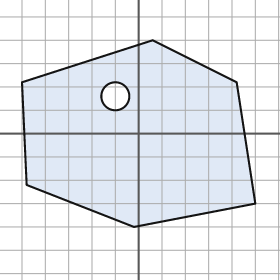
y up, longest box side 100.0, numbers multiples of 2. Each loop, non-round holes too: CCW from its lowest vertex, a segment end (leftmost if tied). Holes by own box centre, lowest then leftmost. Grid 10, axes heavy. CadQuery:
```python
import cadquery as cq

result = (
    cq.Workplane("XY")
    .moveTo(-2.0, -40.0)
    .lineTo(50.0, -30.0)
    .lineTo(42.0, 22.0)
    .lineTo(6.0, 40.0)
    .lineTo(-50.0, 22.0)
    .lineTo(-48.0, -22.0)
    .close()
    .moveTo(-10.0, 16.0)
    .circle(6.0)
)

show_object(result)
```